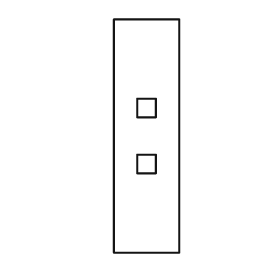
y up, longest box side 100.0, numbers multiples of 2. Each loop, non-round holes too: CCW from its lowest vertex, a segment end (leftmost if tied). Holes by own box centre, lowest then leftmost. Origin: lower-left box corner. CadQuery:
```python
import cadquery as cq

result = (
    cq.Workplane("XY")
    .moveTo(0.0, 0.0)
    .lineTo(28.0, 0.0)
    .lineTo(28.0, 100.0)
    .lineTo(0.0, 100.0)
    .close()
    .moveTo(10.0, 34.0)
    .lineTo(18.0, 34.0)
    .lineTo(18.0, 42.0)
    .lineTo(10.0, 42.0)
    .close()
    .moveTo(10.0, 58.0)
    .lineTo(18.0, 58.0)
    .lineTo(18.0, 66.0)
    .lineTo(10.0, 66.0)
    .close()
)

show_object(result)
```